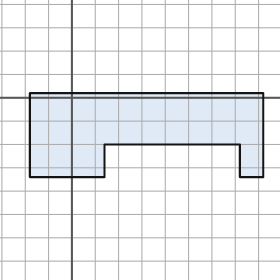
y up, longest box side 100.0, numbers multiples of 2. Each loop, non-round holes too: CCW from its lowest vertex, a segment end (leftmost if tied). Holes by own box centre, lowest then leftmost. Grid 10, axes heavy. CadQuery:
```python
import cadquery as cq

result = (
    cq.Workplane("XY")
    .moveTo(-18.0, -34.0)
    .lineTo(14.0, -34.0)
    .lineTo(14.0, -20.0)
    .lineTo(72.0, -20.0)
    .lineTo(72.0, -34.0)
    .lineTo(82.0, -34.0)
    .lineTo(82.0, 2.0)
    .lineTo(-18.0, 2.0)
    .close()
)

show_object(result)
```